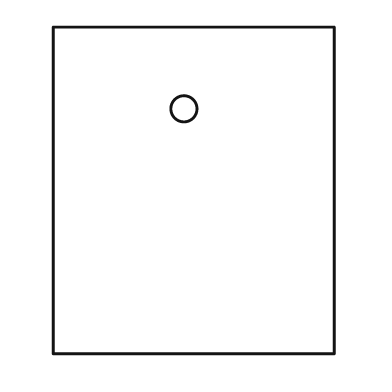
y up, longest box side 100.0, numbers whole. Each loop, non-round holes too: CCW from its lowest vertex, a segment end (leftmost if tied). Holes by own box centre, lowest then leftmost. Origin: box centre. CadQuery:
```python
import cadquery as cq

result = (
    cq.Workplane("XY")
    .moveTo(-43.0, -50.0)
    .lineTo(43.0, -50.0)
    .lineTo(43.0, 50.0)
    .lineTo(-43.0, 50.0)
    .close()
    .moveTo(-3.0, 25.0)
    .circle(4.0)
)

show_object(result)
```